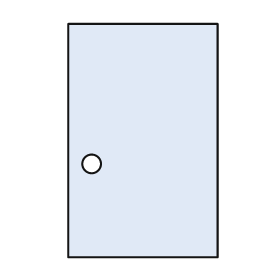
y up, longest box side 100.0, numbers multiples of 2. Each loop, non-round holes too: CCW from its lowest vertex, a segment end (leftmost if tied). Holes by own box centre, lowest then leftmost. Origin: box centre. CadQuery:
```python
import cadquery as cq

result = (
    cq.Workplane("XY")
    .moveTo(-32.0, -50.0)
    .lineTo(32.0, -50.0)
    .lineTo(32.0, 50.0)
    .lineTo(-32.0, 50.0)
    .close()
    .moveTo(-22.0, -10.0)
    .circle(4.0)
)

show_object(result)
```